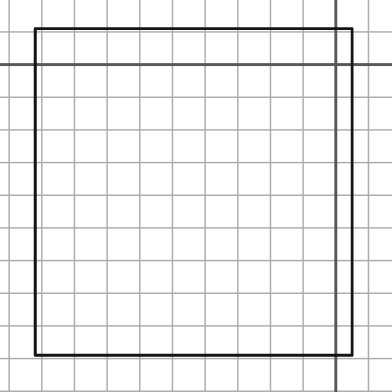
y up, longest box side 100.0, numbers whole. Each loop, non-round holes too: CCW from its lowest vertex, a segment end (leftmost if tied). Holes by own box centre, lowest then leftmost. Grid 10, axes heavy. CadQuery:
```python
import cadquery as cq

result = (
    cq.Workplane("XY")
    .moveTo(-92.0, -89.0)
    .lineTo(5.0, -89.0)
    .lineTo(5.0, 11.0)
    .lineTo(-92.0, 11.0)
    .close()
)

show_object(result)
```